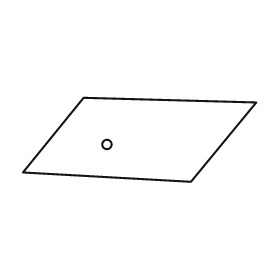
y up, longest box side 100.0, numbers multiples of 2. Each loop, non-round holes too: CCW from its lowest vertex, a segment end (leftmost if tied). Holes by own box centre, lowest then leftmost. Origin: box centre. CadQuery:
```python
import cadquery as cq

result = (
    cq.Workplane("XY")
    .moveTo(22.0, -18.0)
    .lineTo(50.0, 16.0)
    .lineTo(-24.0, 18.0)
    .lineTo(-50.0, -14.0)
    .close()
    .moveTo(-14.0, -2.0)
    .circle(2.0)
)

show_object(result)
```